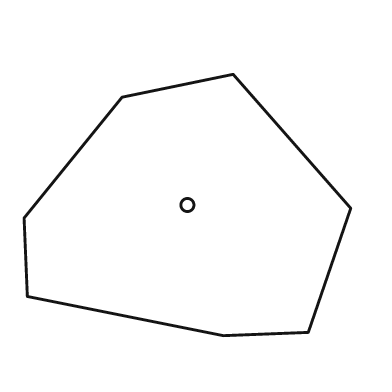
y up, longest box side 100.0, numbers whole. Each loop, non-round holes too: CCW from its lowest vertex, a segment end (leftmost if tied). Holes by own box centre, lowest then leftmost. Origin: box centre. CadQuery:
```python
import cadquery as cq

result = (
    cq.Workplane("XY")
    .moveTo(11.0, -40.0)
    .lineTo(37.0, -39.0)
    .lineTo(50.0, -1.0)
    .lineTo(14.0, 40.0)
    .lineTo(-20.0, 33.0)
    .lineTo(-50.0, -4.0)
    .lineTo(-49.0, -28.0)
    .close()
    .moveTo(0.0, 0.0)
    .circle(2.0)
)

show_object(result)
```